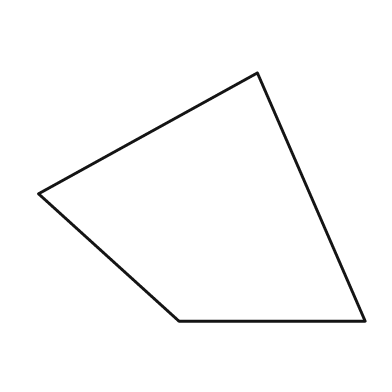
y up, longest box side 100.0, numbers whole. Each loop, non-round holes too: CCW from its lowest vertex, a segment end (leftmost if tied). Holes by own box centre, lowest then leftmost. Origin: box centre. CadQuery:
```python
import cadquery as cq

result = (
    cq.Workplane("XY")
    .moveTo(-7.0, -38.0)
    .lineTo(50.0, -38.0)
    .lineTo(17.0, 38.0)
    .lineTo(-50.0, 1.0)
    .close()
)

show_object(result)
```